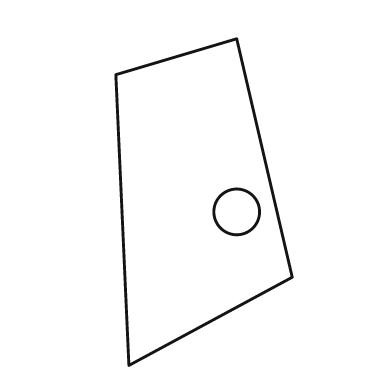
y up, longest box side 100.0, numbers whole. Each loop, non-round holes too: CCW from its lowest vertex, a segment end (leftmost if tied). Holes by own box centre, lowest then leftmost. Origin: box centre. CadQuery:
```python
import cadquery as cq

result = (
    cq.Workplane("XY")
    .moveTo(-23.0, -50.0)
    .lineTo(27.0, -23.0)
    .lineTo(10.0, 50.0)
    .lineTo(-27.0, 39.0)
    .close()
    .moveTo(10.0, -3.0)
    .circle(7.0)
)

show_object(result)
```